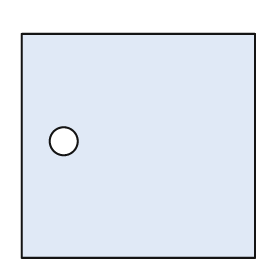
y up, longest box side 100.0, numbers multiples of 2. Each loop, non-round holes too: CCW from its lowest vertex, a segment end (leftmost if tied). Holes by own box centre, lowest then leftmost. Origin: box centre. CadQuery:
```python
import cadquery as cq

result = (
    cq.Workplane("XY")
    .moveTo(-50.0, -48.0)
    .lineTo(50.0, -48.0)
    .lineTo(50.0, 48.0)
    .lineTo(-50.0, 48.0)
    .close()
    .moveTo(-32.0, 2.0)
    .circle(6.0)
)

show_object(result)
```